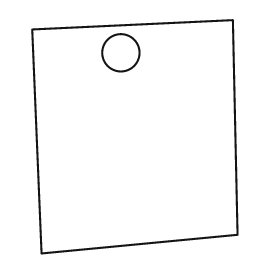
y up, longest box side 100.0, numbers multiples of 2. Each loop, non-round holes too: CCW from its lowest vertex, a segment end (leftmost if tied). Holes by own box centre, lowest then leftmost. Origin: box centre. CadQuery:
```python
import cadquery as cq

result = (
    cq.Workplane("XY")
    .moveTo(-40.0, -50.0)
    .lineTo(44.0, -42.0)
    .lineTo(42.0, 50.0)
    .lineTo(-44.0, 46.0)
    .close()
    .moveTo(-6.0, 36.0)
    .circle(8.0)
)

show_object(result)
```